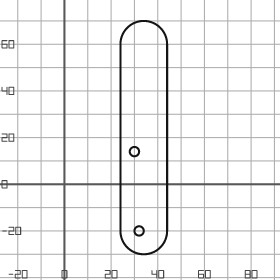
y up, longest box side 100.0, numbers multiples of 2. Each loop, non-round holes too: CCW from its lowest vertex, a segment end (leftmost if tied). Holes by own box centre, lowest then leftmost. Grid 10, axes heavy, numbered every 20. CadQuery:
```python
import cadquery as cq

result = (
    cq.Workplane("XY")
    .moveTo(24.0, -20.0)
    .threePointArc((34.0, -30.0), (44.0, -20.0))
    .lineTo(44.0, 60.0)
    .threePointArc((34.0, 70.0), (24.0, 60.0))
    .close()
    .moveTo(32.0, -20.0)
    .circle(2.0)
    .moveTo(30.0, 14.0)
    .circle(2.0)
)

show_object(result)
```